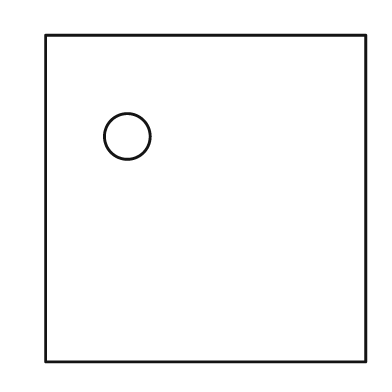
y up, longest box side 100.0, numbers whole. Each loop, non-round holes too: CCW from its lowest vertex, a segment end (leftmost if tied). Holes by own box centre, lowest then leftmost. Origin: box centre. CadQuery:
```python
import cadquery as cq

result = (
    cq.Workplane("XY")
    .moveTo(-49.0, -50.0)
    .lineTo(49.0, -50.0)
    .lineTo(49.0, 50.0)
    .lineTo(-49.0, 50.0)
    .close()
    .moveTo(-24.0, 19.0)
    .circle(7.0)
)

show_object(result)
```